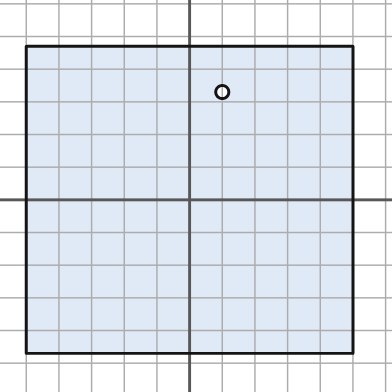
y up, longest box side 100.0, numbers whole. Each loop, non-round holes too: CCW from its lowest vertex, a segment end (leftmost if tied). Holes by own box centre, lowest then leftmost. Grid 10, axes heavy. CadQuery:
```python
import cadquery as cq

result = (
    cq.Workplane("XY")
    .moveTo(-50.0, -47.0)
    .lineTo(50.0, -47.0)
    .lineTo(50.0, 47.0)
    .lineTo(-50.0, 47.0)
    .close()
    .moveTo(10.0, 33.0)
    .circle(2.0)
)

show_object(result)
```